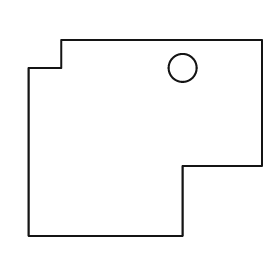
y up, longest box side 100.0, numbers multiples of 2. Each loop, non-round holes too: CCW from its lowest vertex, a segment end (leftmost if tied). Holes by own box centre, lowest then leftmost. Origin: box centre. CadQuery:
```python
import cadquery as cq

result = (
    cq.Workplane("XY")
    .moveTo(-50.0, -42.0)
    .lineTo(16.0, -42.0)
    .lineTo(16.0, -12.0)
    .lineTo(50.0, -12.0)
    .lineTo(50.0, 42.0)
    .lineTo(-36.0, 42.0)
    .lineTo(-36.0, 30.0)
    .lineTo(-50.0, 30.0)
    .close()
    .moveTo(16.0, 30.0)
    .circle(6.0)
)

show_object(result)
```